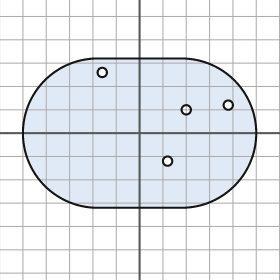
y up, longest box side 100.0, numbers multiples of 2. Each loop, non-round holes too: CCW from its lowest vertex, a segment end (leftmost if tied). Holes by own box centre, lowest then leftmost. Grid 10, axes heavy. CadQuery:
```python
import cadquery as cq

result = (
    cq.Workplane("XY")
    .moveTo(-18.0, -32.0)
    .lineTo(18.0, -32.0)
    .threePointArc((50.0, 0.0), (18.0, 32.0))
    .lineTo(-18.0, 32.0)
    .threePointArc((-50.0, 0.0), (-18.0, -32.0))
    .close()
    .moveTo(12.0, -12.0)
    .circle(2.0)
    .moveTo(20.0, 10.0)
    .circle(2.0)
    .moveTo(38.0, 12.0)
    .circle(2.0)
    .moveTo(-16.0, 26.0)
    .circle(2.0)
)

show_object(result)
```